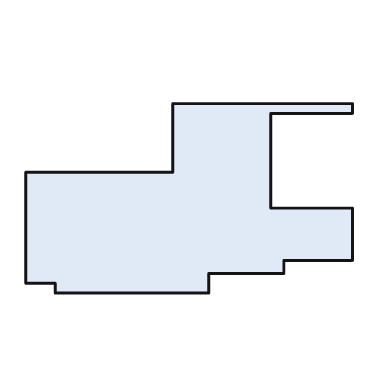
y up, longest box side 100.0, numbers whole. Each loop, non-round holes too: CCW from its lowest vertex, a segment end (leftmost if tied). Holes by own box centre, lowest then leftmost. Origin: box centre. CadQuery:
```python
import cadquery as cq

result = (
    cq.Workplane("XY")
    .moveTo(-41.0, -29.0)
    .lineTo(6.0, -29.0)
    .lineTo(6.0, -23.0)
    .lineTo(29.0, -23.0)
    .lineTo(29.0, -19.0)
    .lineTo(50.0, -19.0)
    .lineTo(50.0, -3.0)
    .lineTo(25.0, -3.0)
    .lineTo(25.0, 26.0)
    .lineTo(50.0, 26.0)
    .lineTo(50.0, 29.0)
    .lineTo(-5.0, 29.0)
    .lineTo(-5.0, 8.0)
    .lineTo(-50.0, 8.0)
    .lineTo(-50.0, -26.0)
    .lineTo(-41.0, -26.0)
    .close()
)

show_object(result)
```